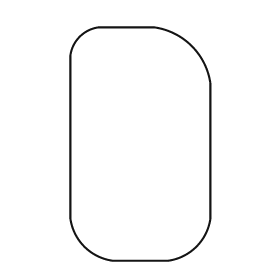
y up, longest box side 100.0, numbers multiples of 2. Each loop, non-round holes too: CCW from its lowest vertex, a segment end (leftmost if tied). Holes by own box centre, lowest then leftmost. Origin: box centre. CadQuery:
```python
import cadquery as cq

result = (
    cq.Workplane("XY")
    .moveTo(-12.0, -50.0)
    .lineTo(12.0, -50.0)
    .threePointArc((24.0, -44.0), (30.0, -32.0))
    .lineTo(30.0, 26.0)
    .threePointArc((22.0, 42.0), (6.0, 50.0))
    .lineTo(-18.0, 50.0)
    .threePointArc((-26.0, 46.0), (-30.0, 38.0))
    .lineTo(-30.0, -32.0)
    .threePointArc((-24.0, -44.0), (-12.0, -50.0))
    .close()
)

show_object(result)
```